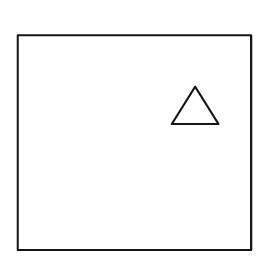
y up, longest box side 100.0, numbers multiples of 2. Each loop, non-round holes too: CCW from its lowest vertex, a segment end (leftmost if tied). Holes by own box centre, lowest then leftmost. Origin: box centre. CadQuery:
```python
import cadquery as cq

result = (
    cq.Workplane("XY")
    .moveTo(-50.0, -46.0)
    .lineTo(50.0, -46.0)
    .lineTo(50.0, 46.0)
    .lineTo(-50.0, 46.0)
    .close()
    .moveTo(16.0, 8.0)
    .lineTo(36.0, 8.0)
    .lineTo(26.0, 24.0)
    .close()
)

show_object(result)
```